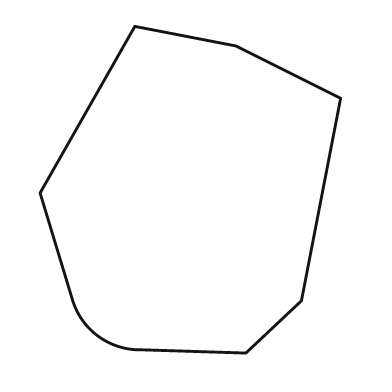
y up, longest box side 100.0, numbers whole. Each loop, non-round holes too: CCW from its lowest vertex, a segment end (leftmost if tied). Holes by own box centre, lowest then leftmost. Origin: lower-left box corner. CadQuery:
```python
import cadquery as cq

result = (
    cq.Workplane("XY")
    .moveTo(63.0, 0.0)
    .lineTo(80.0, 16.0)
    .lineTo(92.0, 78.0)
    .lineTo(60.0, 94.0)
    .lineTo(29.0, 100.0)
    .lineTo(0.0, 49.0)
    .lineTo(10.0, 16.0)
    .threePointArc((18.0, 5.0), (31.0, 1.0))
    .close()
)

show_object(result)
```